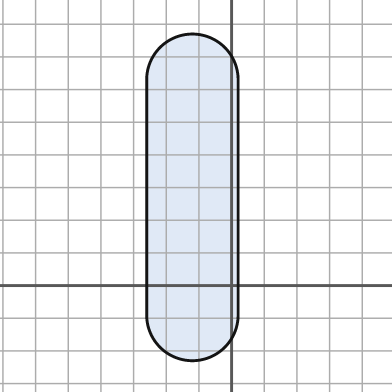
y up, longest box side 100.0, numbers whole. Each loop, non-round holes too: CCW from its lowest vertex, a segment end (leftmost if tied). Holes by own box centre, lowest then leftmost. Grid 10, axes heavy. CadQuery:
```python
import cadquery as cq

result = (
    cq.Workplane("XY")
    .moveTo(-26.0, -9.0)
    .threePointArc((-12.0, -23.0), (2.0, -9.0))
    .lineTo(2.0, 63.0)
    .threePointArc((-12.0, 77.0), (-26.0, 63.0))
    .close()
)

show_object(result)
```